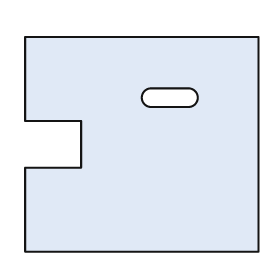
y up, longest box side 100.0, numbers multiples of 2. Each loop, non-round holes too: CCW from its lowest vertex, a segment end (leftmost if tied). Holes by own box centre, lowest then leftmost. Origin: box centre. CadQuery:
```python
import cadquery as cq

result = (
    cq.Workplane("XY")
    .moveTo(-50.0, -46.0)
    .lineTo(50.0, -46.0)
    .lineTo(50.0, 46.0)
    .lineTo(-50.0, 46.0)
    .lineTo(-50.0, 10.0)
    .lineTo(-26.0, 10.0)
    .lineTo(-26.0, -10.0)
    .lineTo(-50.0, -10.0)
    .close()
    .moveTo(4.0, 16.0)
    .lineTo(20.0, 16.0)
    .threePointArc((24.0, 20.0), (20.0, 24.0))
    .lineTo(4.0, 24.0)
    .threePointArc((0.0, 20.0), (4.0, 16.0))
    .close()
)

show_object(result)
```